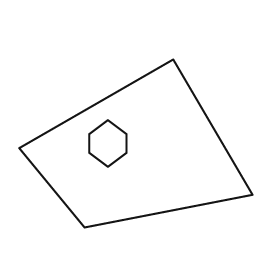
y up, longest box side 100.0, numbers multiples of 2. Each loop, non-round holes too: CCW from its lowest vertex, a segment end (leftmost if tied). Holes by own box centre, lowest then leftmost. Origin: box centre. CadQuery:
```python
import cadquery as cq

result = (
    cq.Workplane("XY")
    .moveTo(-22.0, -36.0)
    .lineTo(50.0, -22.0)
    .lineTo(16.0, 36.0)
    .lineTo(-50.0, -2.0)
    .close()
    .moveTo(-12.0, -10.0)
    .lineTo(-4.0, -4.0)
    .lineTo(-4.0, 4.0)
    .lineTo(-12.0, 10.0)
    .lineTo(-20.0, 4.0)
    .lineTo(-20.0, -4.0)
    .close()
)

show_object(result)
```